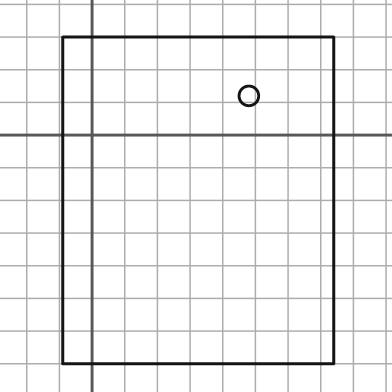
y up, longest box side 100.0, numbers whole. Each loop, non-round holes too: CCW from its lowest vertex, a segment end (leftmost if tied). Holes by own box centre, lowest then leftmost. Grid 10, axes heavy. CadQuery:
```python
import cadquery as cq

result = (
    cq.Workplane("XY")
    .moveTo(-9.0, -70.0)
    .lineTo(74.0, -70.0)
    .lineTo(74.0, 30.0)
    .lineTo(-9.0, 30.0)
    .close()
    .moveTo(48.0, 12.0)
    .circle(3.0)
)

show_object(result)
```